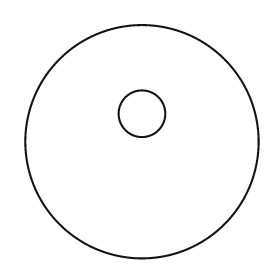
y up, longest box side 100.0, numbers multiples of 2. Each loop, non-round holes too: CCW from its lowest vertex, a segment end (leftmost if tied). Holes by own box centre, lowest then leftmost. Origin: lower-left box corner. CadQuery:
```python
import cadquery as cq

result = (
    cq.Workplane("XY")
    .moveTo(50.0, 50.0)
    .circle(50.0)
    .moveTo(50.0, 62.0)
    .circle(10.0)
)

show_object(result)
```